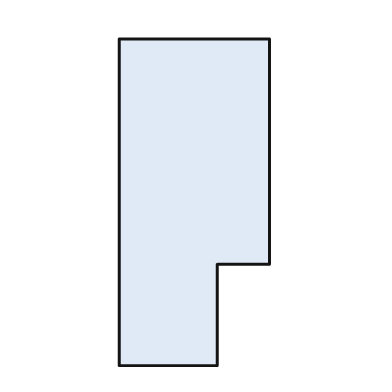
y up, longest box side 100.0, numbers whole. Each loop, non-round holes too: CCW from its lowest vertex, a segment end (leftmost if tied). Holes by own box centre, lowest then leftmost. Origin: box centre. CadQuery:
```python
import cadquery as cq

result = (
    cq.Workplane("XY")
    .moveTo(-23.0, -50.0)
    .lineTo(7.0, -50.0)
    .lineTo(7.0, -19.0)
    .lineTo(23.0, -19.0)
    .lineTo(23.0, 50.0)
    .lineTo(-23.0, 50.0)
    .close()
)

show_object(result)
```